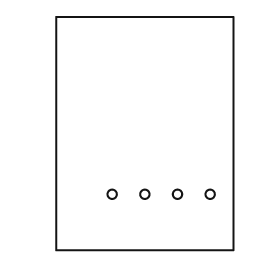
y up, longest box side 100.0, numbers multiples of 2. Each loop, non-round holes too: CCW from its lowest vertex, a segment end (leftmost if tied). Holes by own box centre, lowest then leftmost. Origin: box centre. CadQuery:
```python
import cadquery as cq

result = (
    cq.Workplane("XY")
    .moveTo(-38.0, -50.0)
    .lineTo(38.0, -50.0)
    .lineTo(38.0, 50.0)
    .lineTo(-38.0, 50.0)
    .close()
    .moveTo(-14.0, -26.0)
    .circle(2.0)
    .moveTo(0.0, -26.0)
    .circle(2.0)
    .moveTo(14.0, -26.0)
    .circle(2.0)
    .moveTo(28.0, -26.0)
    .circle(2.0)
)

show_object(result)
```